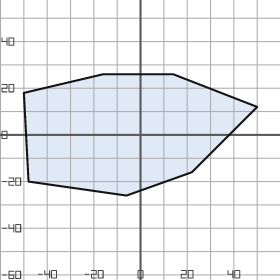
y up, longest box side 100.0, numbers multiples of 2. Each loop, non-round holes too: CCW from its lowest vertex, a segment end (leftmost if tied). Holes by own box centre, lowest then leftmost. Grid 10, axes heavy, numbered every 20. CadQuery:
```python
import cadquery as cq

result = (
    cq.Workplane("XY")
    .moveTo(-6.0, -26.0)
    .lineTo(22.0, -16.0)
    .lineTo(50.0, 12.0)
    .lineTo(14.0, 26.0)
    .lineTo(-16.0, 26.0)
    .lineTo(-50.0, 18.0)
    .lineTo(-48.0, -20.0)
    .close()
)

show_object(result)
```